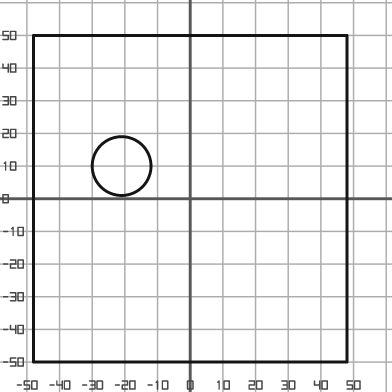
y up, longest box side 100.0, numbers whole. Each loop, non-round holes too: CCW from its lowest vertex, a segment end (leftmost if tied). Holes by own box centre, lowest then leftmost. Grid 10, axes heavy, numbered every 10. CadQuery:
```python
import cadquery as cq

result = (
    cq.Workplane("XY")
    .moveTo(-48.0, -50.0)
    .lineTo(48.0, -50.0)
    .lineTo(48.0, 50.0)
    .lineTo(-48.0, 50.0)
    .close()
    .moveTo(-21.0, 10.0)
    .circle(9.0)
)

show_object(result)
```